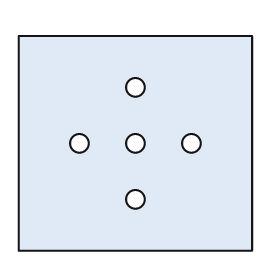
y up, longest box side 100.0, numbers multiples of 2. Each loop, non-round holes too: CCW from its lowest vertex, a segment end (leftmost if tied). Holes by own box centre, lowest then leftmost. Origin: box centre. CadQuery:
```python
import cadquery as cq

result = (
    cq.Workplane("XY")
    .moveTo(-50.0, -46.0)
    .lineTo(50.0, -46.0)
    .lineTo(50.0, 46.0)
    .lineTo(-50.0, 46.0)
    .close()
    .moveTo(0.0, -24.0)
    .circle(4.0)
    .moveTo(-24.0, 0.0)
    .circle(4.0)
    .moveTo(0.0, 0.0)
    .circle(4.0)
    .moveTo(24.0, 0.0)
    .circle(4.0)
    .moveTo(0.0, 24.0)
    .circle(4.0)
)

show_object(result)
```